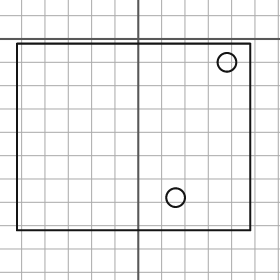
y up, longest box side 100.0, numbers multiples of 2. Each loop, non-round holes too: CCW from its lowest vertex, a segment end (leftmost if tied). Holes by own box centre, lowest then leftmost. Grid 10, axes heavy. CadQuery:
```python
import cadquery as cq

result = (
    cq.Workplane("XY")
    .moveTo(-52.0, -82.0)
    .lineTo(48.0, -82.0)
    .lineTo(48.0, -2.0)
    .lineTo(-52.0, -2.0)
    .close()
    .moveTo(16.0, -68.0)
    .circle(4.0)
    .moveTo(38.0, -10.0)
    .circle(4.0)
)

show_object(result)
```